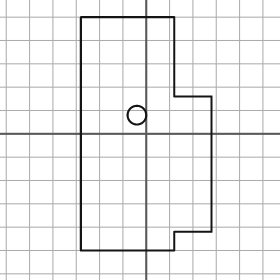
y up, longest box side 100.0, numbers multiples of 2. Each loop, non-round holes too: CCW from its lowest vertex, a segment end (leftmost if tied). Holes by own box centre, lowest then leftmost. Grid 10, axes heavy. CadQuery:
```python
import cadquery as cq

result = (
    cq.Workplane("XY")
    .moveTo(-28.0, -50.0)
    .lineTo(12.0, -50.0)
    .lineTo(12.0, -42.0)
    .lineTo(28.0, -42.0)
    .lineTo(28.0, 16.0)
    .lineTo(12.0, 16.0)
    .lineTo(12.0, 50.0)
    .lineTo(-28.0, 50.0)
    .close()
    .moveTo(-4.0, 8.0)
    .circle(4.0)
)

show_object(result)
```